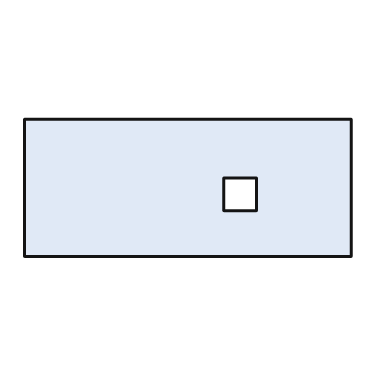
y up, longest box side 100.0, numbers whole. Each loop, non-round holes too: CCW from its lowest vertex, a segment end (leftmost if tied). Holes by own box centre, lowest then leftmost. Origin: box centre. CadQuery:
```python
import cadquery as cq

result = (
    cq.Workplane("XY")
    .moveTo(-50.0, -21.0)
    .lineTo(50.0, -21.0)
    .lineTo(50.0, 21.0)
    .lineTo(-50.0, 21.0)
    .close()
    .moveTo(11.0, -7.0)
    .lineTo(21.0, -7.0)
    .lineTo(21.0, 3.0)
    .lineTo(11.0, 3.0)
    .close()
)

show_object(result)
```